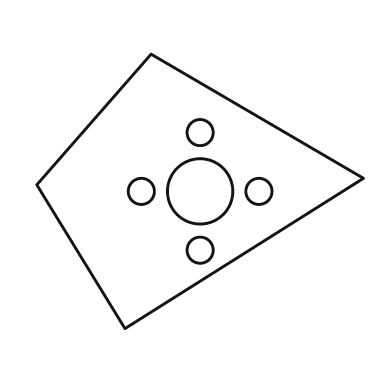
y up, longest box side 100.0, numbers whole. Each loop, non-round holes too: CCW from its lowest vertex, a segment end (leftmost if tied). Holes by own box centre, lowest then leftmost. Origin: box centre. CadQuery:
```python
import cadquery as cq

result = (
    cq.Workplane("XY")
    .moveTo(-23.0, -42.0)
    .lineTo(50.0, 4.0)
    .lineTo(-15.0, 42.0)
    .lineTo(-50.0, 2.0)
    .close()
    .moveTo(0.0, -18.0)
    .circle(4.0)
    .moveTo(-18.0, 0.0)
    .circle(4.0)
    .moveTo(0.0, 0.0)
    .circle(10.0)
    .moveTo(18.0, 0.0)
    .circle(4.0)
    .moveTo(0.0, 18.0)
    .circle(4.0)
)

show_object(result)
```